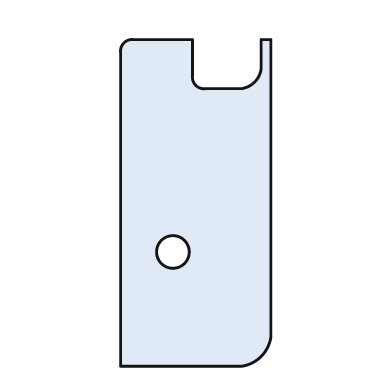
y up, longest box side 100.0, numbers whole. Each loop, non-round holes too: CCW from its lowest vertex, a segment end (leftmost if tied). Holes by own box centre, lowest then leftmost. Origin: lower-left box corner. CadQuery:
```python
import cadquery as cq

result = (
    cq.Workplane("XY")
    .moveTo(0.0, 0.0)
    .lineTo(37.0, 0.0)
    .threePointArc((43.0, 3.0), (46.0, 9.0))
    .lineTo(46.0, 100.0)
    .lineTo(43.0, 100.0)
    .lineTo(43.0, 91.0)
    .threePointArc((41.0, 87.0), (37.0, 85.0))
    .lineTo(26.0, 85.0)
    .threePointArc((23.0, 86.0), (22.0, 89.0))
    .lineTo(22.0, 100.0)
    .lineTo(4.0, 100.0)
    .threePointArc((1.0, 99.0), (0.0, 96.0))
    .close()
    .moveTo(16.0, 35.0)
    .circle(5.0)
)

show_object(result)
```